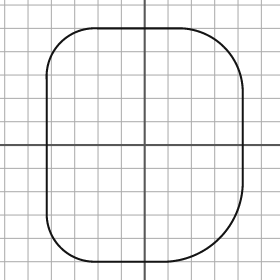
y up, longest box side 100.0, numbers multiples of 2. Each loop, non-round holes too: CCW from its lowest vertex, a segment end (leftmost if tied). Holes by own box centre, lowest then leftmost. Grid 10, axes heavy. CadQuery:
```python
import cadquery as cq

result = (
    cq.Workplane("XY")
    .moveTo(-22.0, -50.0)
    .lineTo(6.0, -50.0)
    .threePointArc((32.0, -40.0), (42.0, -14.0))
    .lineTo(42.0, 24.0)
    .threePointArc((34.0, 42.0), (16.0, 50.0))
    .lineTo(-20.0, 50.0)
    .threePointArc((-36.0, 44.0), (-42.0, 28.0))
    .lineTo(-42.0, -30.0)
    .threePointArc((-36.0, -44.0), (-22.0, -50.0))
    .close()
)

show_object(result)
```